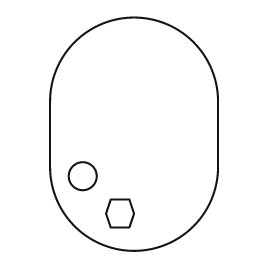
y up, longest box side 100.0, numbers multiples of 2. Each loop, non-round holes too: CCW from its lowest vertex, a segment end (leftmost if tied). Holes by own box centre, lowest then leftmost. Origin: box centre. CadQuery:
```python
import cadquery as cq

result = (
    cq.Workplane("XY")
    .moveTo(-36.0, -14.0)
    .threePointArc((0.0, -50.0), (36.0, -14.0))
    .lineTo(36.0, 14.0)
    .threePointArc((0.0, 50.0), (-36.0, 14.0))
    .close()
    .moveTo(-10.0, -40.0)
    .lineTo(-2.0, -40.0)
    .lineTo(0.0, -34.0)
    .lineTo(-2.0, -28.0)
    .lineTo(-10.0, -28.0)
    .lineTo(-12.0, -34.0)
    .close()
    .moveTo(-22.0, -18.0)
    .circle(6.0)
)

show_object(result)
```